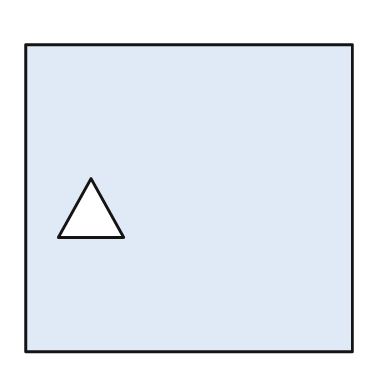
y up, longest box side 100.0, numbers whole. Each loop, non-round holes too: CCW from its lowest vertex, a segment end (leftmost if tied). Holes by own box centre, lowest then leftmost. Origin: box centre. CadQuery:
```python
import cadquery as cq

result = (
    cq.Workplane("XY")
    .moveTo(-50.0, -47.0)
    .lineTo(50.0, -47.0)
    .lineTo(50.0, 47.0)
    .lineTo(-50.0, 47.0)
    .close()
    .moveTo(-40.0, -12.0)
    .lineTo(-20.0, -12.0)
    .lineTo(-30.0, 6.0)
    .close()
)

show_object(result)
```